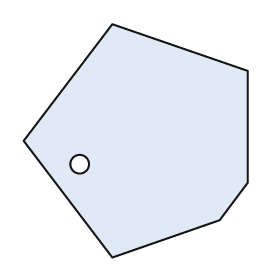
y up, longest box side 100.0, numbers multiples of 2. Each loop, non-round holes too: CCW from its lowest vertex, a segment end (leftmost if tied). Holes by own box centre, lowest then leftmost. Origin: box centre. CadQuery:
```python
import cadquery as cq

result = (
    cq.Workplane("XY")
    .moveTo(-10.0, -50.0)
    .lineTo(36.0, -34.0)
    .lineTo(48.0, -18.0)
    .lineTo(48.0, 30.0)
    .lineTo(-10.0, 50.0)
    .lineTo(-48.0, 0.0)
    .close()
    .moveTo(-24.0, -10.0)
    .circle(4.0)
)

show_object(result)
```